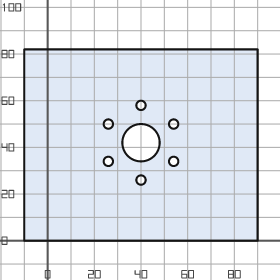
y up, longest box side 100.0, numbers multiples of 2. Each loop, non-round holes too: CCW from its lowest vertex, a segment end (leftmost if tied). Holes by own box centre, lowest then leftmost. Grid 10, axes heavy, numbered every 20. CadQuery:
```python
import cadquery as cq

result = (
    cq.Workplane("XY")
    .moveTo(-10.0, 0.0)
    .lineTo(90.0, 0.0)
    .lineTo(90.0, 82.0)
    .lineTo(-10.0, 82.0)
    .close()
    .moveTo(40.0, 26.0)
    .circle(2.0)
    .moveTo(26.0, 34.0)
    .circle(2.0)
    .moveTo(54.0, 34.0)
    .circle(2.0)
    .moveTo(40.0, 42.0)
    .circle(8.0)
    .moveTo(26.0, 50.0)
    .circle(2.0)
    .moveTo(54.0, 50.0)
    .circle(2.0)
    .moveTo(40.0, 58.0)
    .circle(2.0)
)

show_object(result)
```